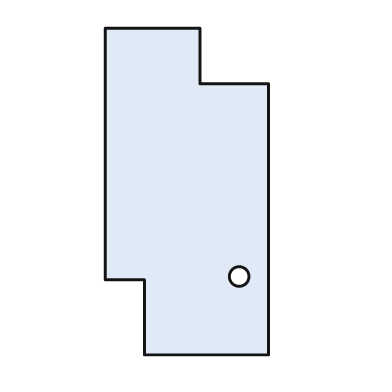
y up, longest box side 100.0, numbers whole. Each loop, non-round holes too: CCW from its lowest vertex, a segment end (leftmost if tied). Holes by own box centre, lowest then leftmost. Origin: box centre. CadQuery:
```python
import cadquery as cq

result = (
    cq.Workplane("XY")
    .moveTo(-13.0, -50.0)
    .lineTo(25.0, -50.0)
    .lineTo(25.0, 33.0)
    .lineTo(4.0, 33.0)
    .lineTo(4.0, 50.0)
    .lineTo(-25.0, 50.0)
    .lineTo(-25.0, -27.0)
    .lineTo(-13.0, -27.0)
    .close()
    .moveTo(16.0, -26.0)
    .circle(3.0)
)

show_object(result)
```